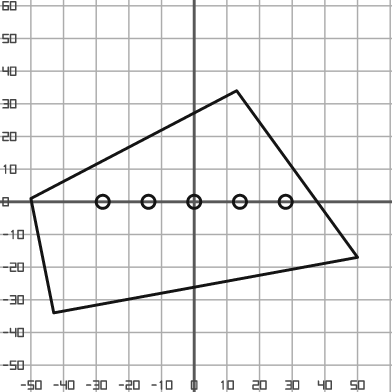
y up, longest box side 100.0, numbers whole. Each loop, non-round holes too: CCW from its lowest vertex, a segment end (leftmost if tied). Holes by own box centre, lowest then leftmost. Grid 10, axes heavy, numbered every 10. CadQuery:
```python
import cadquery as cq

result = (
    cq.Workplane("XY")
    .moveTo(-43.0, -34.0)
    .lineTo(50.0, -17.0)
    .lineTo(13.0, 34.0)
    .lineTo(-50.0, 1.0)
    .close()
    .moveTo(-28.0, 0.0)
    .circle(2.0)
    .moveTo(-14.0, 0.0)
    .circle(2.0)
    .moveTo(0.0, 0.0)
    .circle(2.0)
    .moveTo(14.0, 0.0)
    .circle(2.0)
    .moveTo(28.0, 0.0)
    .circle(2.0)
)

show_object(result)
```